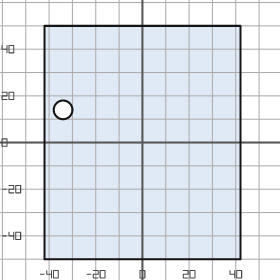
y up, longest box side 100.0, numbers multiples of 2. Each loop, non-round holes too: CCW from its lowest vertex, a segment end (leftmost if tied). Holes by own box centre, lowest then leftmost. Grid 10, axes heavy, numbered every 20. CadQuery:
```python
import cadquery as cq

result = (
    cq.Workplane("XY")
    .moveTo(-42.0, -50.0)
    .lineTo(42.0, -50.0)
    .lineTo(42.0, 50.0)
    .lineTo(-42.0, 50.0)
    .close()
    .moveTo(-34.0, 14.0)
    .circle(4.0)
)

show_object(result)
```